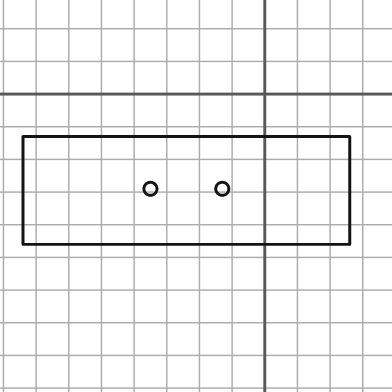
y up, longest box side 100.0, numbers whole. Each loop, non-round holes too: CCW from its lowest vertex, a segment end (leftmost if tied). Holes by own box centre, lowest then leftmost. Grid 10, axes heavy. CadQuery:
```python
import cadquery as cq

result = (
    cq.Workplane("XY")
    .moveTo(-74.0, -46.0)
    .lineTo(26.0, -46.0)
    .lineTo(26.0, -13.0)
    .lineTo(-74.0, -13.0)
    .close()
    .moveTo(-35.0, -29.0)
    .circle(2.0)
    .moveTo(-13.0, -29.0)
    .circle(2.0)
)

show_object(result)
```